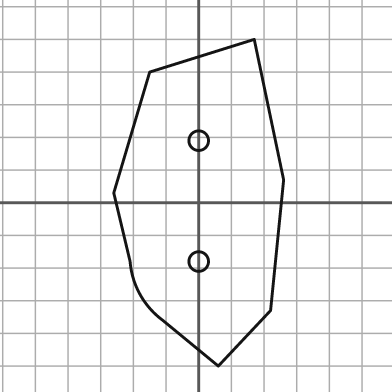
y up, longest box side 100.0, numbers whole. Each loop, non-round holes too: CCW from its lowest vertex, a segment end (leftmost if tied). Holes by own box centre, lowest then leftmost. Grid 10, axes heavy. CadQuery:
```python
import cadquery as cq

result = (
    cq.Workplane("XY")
    .moveTo(6.0, -50.0)
    .lineTo(22.0, -33.0)
    .lineTo(26.0, 7.0)
    .lineTo(17.0, 50.0)
    .lineTo(-15.0, 40.0)
    .lineTo(-26.0, 3.0)
    .lineTo(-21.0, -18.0)
    .threePointArc((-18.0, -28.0), (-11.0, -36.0))
    .close()
    .moveTo(0.0, -18.0)
    .circle(3.0)
    .moveTo(0.0, 19.0)
    .circle(3.0)
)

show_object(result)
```